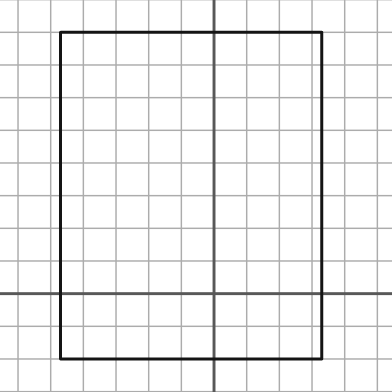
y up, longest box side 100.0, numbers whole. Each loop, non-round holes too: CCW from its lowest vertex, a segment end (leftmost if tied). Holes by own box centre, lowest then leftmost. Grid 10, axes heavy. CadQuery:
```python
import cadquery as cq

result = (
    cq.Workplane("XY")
    .moveTo(-47.0, -20.0)
    .lineTo(33.0, -20.0)
    .lineTo(33.0, 80.0)
    .lineTo(-47.0, 80.0)
    .close()
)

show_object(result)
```